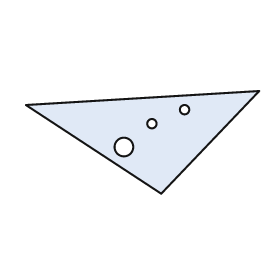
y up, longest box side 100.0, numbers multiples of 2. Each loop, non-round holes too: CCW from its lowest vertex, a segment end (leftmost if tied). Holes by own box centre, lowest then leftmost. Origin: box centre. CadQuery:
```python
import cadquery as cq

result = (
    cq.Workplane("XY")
    .moveTo(8.0, -22.0)
    .lineTo(50.0, 22.0)
    .lineTo(-50.0, 16.0)
    .close()
    .moveTo(-8.0, -2.0)
    .circle(4.0)
    .moveTo(4.0, 8.0)
    .circle(2.0)
    .moveTo(18.0, 14.0)
    .circle(2.0)
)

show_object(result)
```